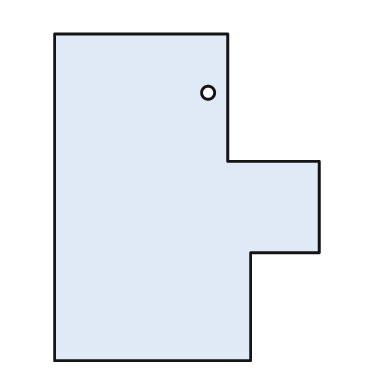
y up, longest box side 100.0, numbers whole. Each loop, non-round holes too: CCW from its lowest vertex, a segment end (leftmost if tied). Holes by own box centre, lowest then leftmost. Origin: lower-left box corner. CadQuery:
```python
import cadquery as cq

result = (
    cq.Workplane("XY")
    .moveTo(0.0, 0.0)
    .lineTo(60.0, 0.0)
    .lineTo(60.0, 33.0)
    .lineTo(81.0, 33.0)
    .lineTo(81.0, 61.0)
    .lineTo(53.0, 61.0)
    .lineTo(53.0, 100.0)
    .lineTo(0.0, 100.0)
    .close()
    .moveTo(47.0, 82.0)
    .circle(2.0)
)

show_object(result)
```